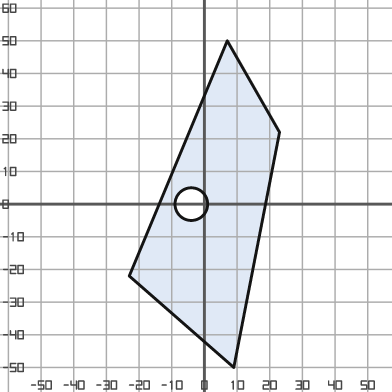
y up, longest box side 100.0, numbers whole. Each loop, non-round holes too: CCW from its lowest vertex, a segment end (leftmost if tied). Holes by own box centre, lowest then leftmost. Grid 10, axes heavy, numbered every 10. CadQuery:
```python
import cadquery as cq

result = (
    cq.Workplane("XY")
    .moveTo(9.0, -50.0)
    .lineTo(23.0, 22.0)
    .lineTo(7.0, 50.0)
    .lineTo(-23.0, -22.0)
    .close()
    .moveTo(-4.0, 0.0)
    .circle(5.0)
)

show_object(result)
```